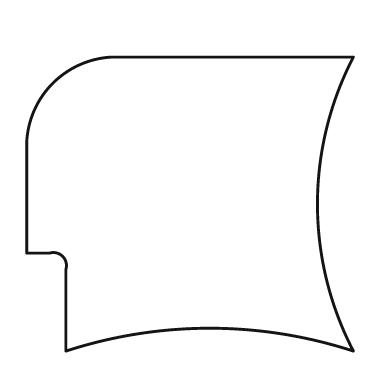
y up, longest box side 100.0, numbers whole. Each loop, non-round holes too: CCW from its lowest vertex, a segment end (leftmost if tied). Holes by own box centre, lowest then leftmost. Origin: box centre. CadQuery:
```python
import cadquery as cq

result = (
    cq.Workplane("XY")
    .moveTo(-38.0, -45.0)
    .threePointArc((6.0, -38.0), (50.0, -45.0))
    .threePointArc((39.0, 0.0), (50.0, 45.0))
    .lineTo(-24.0, 45.0)
    .threePointArc((-42.0, 37.0), (-50.0, 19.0))
    .lineTo(-50.0, -15.0)
    .lineTo(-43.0, -15.0)
    .threePointArc((-39.0, -16.0), (-38.0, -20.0))
    .close()
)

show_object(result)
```